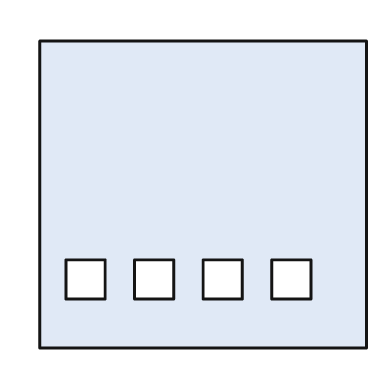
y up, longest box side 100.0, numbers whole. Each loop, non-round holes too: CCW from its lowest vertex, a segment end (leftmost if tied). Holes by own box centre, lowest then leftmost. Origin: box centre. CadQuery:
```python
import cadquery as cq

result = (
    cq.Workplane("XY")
    .moveTo(-50.0, -47.0)
    .lineTo(50.0, -47.0)
    .lineTo(50.0, 47.0)
    .lineTo(-50.0, 47.0)
    .close()
    .moveTo(-42.0, -32.0)
    .lineTo(-30.0, -32.0)
    .lineTo(-30.0, -20.0)
    .lineTo(-42.0, -20.0)
    .close()
    .moveTo(-21.0, -32.0)
    .lineTo(-9.0, -32.0)
    .lineTo(-9.0, -20.0)
    .lineTo(-21.0, -20.0)
    .close()
    .moveTo(0.0, -32.0)
    .lineTo(12.0, -32.0)
    .lineTo(12.0, -20.0)
    .lineTo(0.0, -20.0)
    .close()
    .moveTo(21.0, -32.0)
    .lineTo(33.0, -32.0)
    .lineTo(33.0, -20.0)
    .lineTo(21.0, -20.0)
    .close()
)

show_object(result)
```